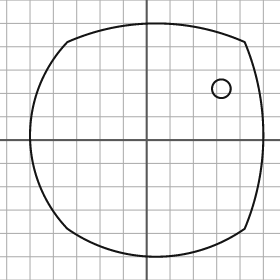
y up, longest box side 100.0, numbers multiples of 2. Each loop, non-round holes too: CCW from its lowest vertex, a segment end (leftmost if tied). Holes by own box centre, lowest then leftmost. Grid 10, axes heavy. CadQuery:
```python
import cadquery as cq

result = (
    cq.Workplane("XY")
    .moveTo(-34.0, -38.0)
    .threePointArc((4.0, -50.0), (42.0, -38.0))
    .threePointArc((50.0, 2.0), (42.0, 42.0))
    .threePointArc((4.0, 50.0), (-34.0, 42.0))
    .threePointArc((-50.0, 2.0), (-34.0, -38.0))
    .close()
    .moveTo(32.0, 22.0)
    .circle(4.0)
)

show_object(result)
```